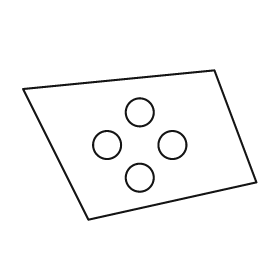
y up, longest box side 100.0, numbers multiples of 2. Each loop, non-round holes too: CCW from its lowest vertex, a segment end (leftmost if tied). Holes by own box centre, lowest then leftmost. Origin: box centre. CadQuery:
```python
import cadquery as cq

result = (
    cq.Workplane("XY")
    .moveTo(-22.0, -32.0)
    .lineTo(50.0, -16.0)
    .lineTo(32.0, 32.0)
    .lineTo(-50.0, 24.0)
    .close()
    .moveTo(0.0, -14.0)
    .circle(6.0)
    .moveTo(-14.0, 0.0)
    .circle(6.0)
    .moveTo(14.0, 0.0)
    .circle(6.0)
    .moveTo(0.0, 14.0)
    .circle(6.0)
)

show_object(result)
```